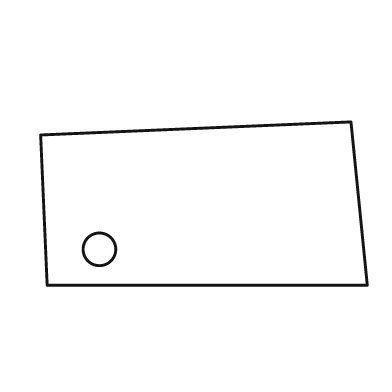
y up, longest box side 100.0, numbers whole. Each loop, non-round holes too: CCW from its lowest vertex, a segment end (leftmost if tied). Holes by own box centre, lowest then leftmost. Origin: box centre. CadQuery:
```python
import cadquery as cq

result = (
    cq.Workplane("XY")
    .moveTo(-48.0, -25.0)
    .lineTo(50.0, -25.0)
    .lineTo(45.0, 25.0)
    .lineTo(-50.0, 21.0)
    .close()
    .moveTo(-32.0, -14.0)
    .circle(5.0)
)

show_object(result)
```